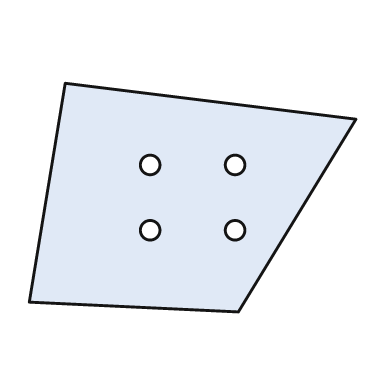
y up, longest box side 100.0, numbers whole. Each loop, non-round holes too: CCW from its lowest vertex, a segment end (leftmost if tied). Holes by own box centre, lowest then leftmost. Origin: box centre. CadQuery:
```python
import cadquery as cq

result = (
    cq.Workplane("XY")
    .moveTo(14.0, -35.0)
    .lineTo(50.0, 24.0)
    .lineTo(-39.0, 35.0)
    .lineTo(-50.0, -32.0)
    .close()
    .moveTo(-13.0, -10.0)
    .circle(3.0)
    .moveTo(13.0, -10.0)
    .circle(3.0)
    .moveTo(-13.0, 10.0)
    .circle(3.0)
    .moveTo(13.0, 10.0)
    .circle(3.0)
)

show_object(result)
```